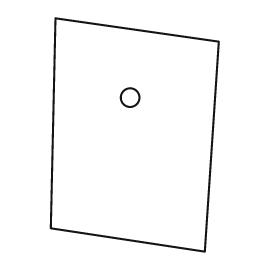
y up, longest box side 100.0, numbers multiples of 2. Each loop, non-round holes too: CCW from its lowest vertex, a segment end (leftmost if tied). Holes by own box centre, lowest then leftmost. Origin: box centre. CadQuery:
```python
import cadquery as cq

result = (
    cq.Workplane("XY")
    .moveTo(30.0, -50.0)
    .lineTo(36.0, 40.0)
    .lineTo(-34.0, 50.0)
    .lineTo(-36.0, -40.0)
    .close()
    .moveTo(-2.0, 16.0)
    .circle(4.0)
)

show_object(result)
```